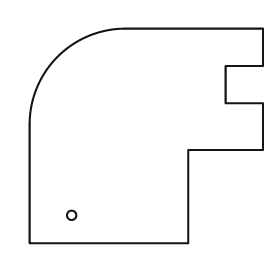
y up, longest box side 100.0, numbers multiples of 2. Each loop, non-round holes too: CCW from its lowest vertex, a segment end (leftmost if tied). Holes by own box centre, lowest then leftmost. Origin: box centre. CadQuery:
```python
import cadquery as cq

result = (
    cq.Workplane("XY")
    .moveTo(-50.0, -46.0)
    .lineTo(18.0, -46.0)
    .lineTo(18.0, -6.0)
    .lineTo(50.0, -6.0)
    .lineTo(50.0, 14.0)
    .lineTo(34.0, 14.0)
    .lineTo(34.0, 30.0)
    .lineTo(50.0, 30.0)
    .lineTo(50.0, 46.0)
    .lineTo(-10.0, 46.0)
    .threePointArc((-38.0, 34.0), (-50.0, 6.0))
    .close()
    .moveTo(-32.0, -34.0)
    .circle(2.0)
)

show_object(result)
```